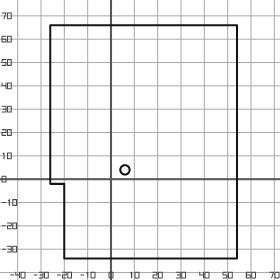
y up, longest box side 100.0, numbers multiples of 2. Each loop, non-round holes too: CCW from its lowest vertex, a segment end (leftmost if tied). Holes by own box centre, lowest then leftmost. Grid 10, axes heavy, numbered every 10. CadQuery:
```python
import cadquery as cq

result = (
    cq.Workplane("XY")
    .moveTo(-20.0, -34.0)
    .lineTo(54.0, -34.0)
    .lineTo(54.0, 66.0)
    .lineTo(-26.0, 66.0)
    .lineTo(-26.0, -2.0)
    .lineTo(-20.0, -2.0)
    .close()
    .moveTo(6.0, 4.0)
    .circle(2.0)
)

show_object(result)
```